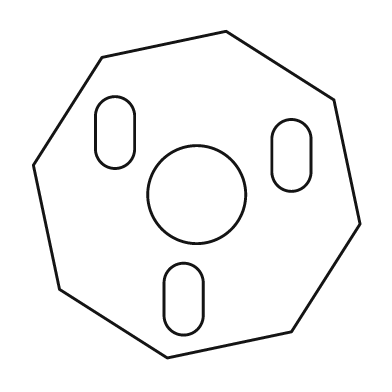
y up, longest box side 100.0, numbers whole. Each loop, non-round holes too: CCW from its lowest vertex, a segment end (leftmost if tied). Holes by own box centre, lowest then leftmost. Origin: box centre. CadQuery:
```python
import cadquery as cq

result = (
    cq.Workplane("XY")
    .moveTo(-9.0, -50.0)
    .lineTo(29.0, -42.0)
    .lineTo(50.0, -9.0)
    .lineTo(42.0, 29.0)
    .lineTo(9.0, 50.0)
    .lineTo(-29.0, 42.0)
    .lineTo(-50.0, 9.0)
    .lineTo(-42.0, -29.0)
    .close()
    .moveTo(-10.0, -37.0)
    .threePointArc((-4.0, -43.0), (2.0, -37.0))
    .lineTo(2.0, -27.0)
    .threePointArc((-4.0, -21.0), (-10.0, -27.0))
    .close()
    .moveTo(0.0, 0.0)
    .circle(15.0)
    .moveTo(23.0, 7.0)
    .threePointArc((29.0, 1.0), (35.0, 7.0))
    .lineTo(35.0, 17.0)
    .threePointArc((29.0, 23.0), (23.0, 17.0))
    .close()
    .moveTo(-31.0, 14.0)
    .threePointArc((-25.0, 8.0), (-19.0, 14.0))
    .lineTo(-19.0, 24.0)
    .threePointArc((-25.0, 30.0), (-31.0, 24.0))
    .close()
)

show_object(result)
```